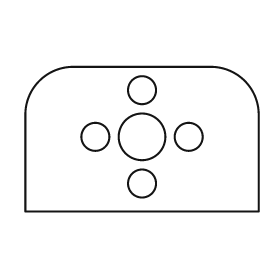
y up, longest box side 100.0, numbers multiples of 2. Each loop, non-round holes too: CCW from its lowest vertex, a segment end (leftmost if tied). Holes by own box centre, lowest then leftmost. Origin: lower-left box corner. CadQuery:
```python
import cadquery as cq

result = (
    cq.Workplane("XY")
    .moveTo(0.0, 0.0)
    .lineTo(100.0, 0.0)
    .lineTo(100.0, 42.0)
    .threePointArc((94.0, 56.0), (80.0, 62.0))
    .lineTo(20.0, 62.0)
    .threePointArc((6.0, 56.0), (0.0, 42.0))
    .close()
    .moveTo(50.0, 12.0)
    .circle(6.0)
    .moveTo(30.0, 32.0)
    .circle(6.0)
    .moveTo(50.0, 32.0)
    .circle(10.0)
    .moveTo(70.0, 32.0)
    .circle(6.0)
    .moveTo(50.0, 52.0)
    .circle(6.0)
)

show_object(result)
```